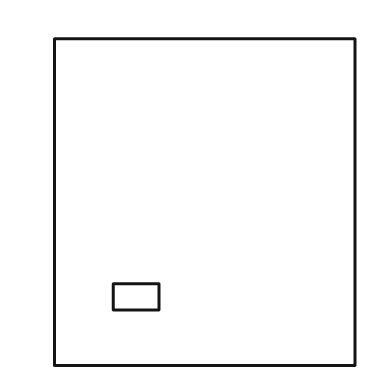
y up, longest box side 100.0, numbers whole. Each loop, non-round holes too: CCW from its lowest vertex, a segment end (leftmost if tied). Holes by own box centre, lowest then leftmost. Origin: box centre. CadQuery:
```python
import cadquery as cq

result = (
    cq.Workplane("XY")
    .moveTo(-46.0, -50.0)
    .lineTo(46.0, -50.0)
    .lineTo(46.0, 50.0)
    .lineTo(-46.0, 50.0)
    .close()
    .moveTo(-28.0, -33.0)
    .lineTo(-14.0, -33.0)
    .lineTo(-14.0, -25.0)
    .lineTo(-28.0, -25.0)
    .close()
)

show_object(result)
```